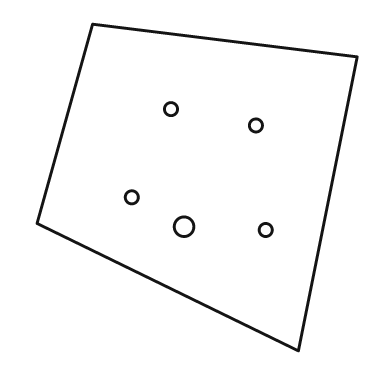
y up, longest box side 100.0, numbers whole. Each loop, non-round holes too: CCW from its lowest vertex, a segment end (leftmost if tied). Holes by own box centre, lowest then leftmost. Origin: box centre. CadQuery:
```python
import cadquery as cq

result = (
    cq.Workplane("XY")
    .moveTo(31.0, -50.0)
    .lineTo(49.0, 40.0)
    .lineTo(-32.0, 50.0)
    .lineTo(-49.0, -11.0)
    .close()
    .moveTo(21.0, -13.0)
    .circle(2.0)
    .moveTo(-4.0, -12.0)
    .circle(3.0)
    .moveTo(-20.0, -3.0)
    .circle(2.0)
    .moveTo(18.0, 19.0)
    .circle(2.0)
    .moveTo(-8.0, 24.0)
    .circle(2.0)
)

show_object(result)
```